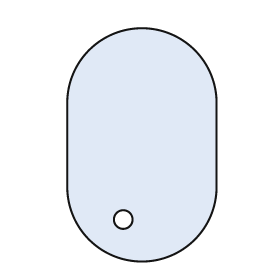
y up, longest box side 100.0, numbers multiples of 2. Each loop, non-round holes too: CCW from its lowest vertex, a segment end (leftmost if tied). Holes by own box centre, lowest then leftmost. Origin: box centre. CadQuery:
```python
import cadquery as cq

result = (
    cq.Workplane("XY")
    .moveTo(-32.0, -18.0)
    .threePointArc((0.0, -50.0), (32.0, -18.0))
    .lineTo(32.0, 18.0)
    .threePointArc((0.0, 50.0), (-32.0, 18.0))
    .close()
    .moveTo(-8.0, -32.0)
    .circle(4.0)
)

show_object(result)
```